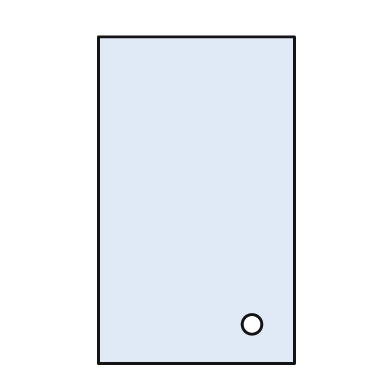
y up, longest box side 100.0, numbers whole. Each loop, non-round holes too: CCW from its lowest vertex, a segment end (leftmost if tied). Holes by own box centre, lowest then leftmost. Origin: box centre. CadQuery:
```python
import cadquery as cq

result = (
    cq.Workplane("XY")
    .moveTo(-30.0, -50.0)
    .lineTo(30.0, -50.0)
    .lineTo(30.0, 50.0)
    .lineTo(-30.0, 50.0)
    .close()
    .moveTo(17.0, -38.0)
    .circle(3.0)
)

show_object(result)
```